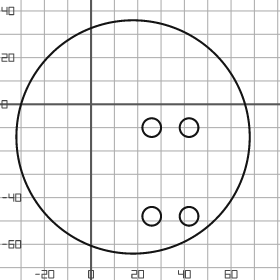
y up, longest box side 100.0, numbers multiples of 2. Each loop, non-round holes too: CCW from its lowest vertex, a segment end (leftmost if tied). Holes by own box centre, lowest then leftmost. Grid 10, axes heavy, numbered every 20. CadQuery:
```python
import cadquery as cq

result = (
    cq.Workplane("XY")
    .moveTo(18.0, -14.0)
    .circle(50.0)
    .moveTo(26.0, -48.0)
    .circle(4.0)
    .moveTo(42.0, -48.0)
    .circle(4.0)
    .moveTo(26.0, -10.0)
    .circle(4.0)
    .moveTo(42.0, -10.0)
    .circle(4.0)
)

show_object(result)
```